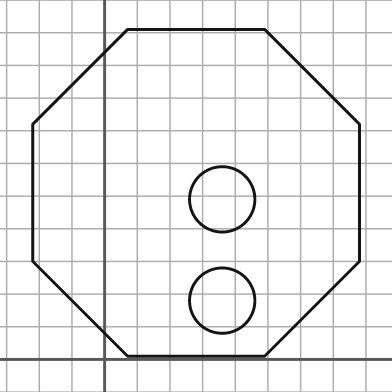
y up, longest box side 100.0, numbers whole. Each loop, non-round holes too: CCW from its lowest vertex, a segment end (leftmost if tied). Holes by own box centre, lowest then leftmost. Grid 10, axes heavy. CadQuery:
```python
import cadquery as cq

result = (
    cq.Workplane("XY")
    .moveTo(7.0, 1.0)
    .lineTo(49.0, 1.0)
    .lineTo(78.0, 30.0)
    .lineTo(78.0, 72.0)
    .lineTo(49.0, 101.0)
    .lineTo(7.0, 101.0)
    .lineTo(-22.0, 72.0)
    .lineTo(-22.0, 30.0)
    .close()
    .moveTo(36.0, 18.0)
    .circle(10.0)
    .moveTo(36.0, 49.0)
    .circle(10.0)
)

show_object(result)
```